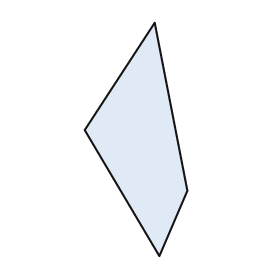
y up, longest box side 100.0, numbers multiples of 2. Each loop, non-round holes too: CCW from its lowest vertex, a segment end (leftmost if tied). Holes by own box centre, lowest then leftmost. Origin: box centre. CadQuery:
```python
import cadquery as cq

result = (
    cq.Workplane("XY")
    .moveTo(10.0, -50.0)
    .lineTo(22.0, -22.0)
    .lineTo(8.0, 50.0)
    .lineTo(-22.0, 4.0)
    .close()
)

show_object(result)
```